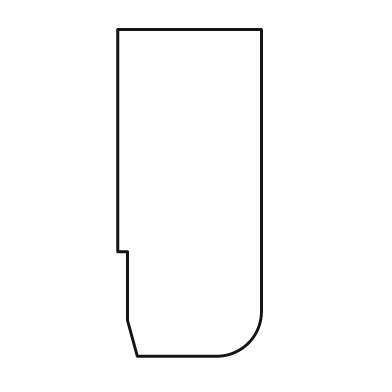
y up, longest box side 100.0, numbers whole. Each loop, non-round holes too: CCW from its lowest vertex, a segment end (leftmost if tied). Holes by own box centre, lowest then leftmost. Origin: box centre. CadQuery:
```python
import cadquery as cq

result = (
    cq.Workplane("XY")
    .moveTo(-16.0, -50.0)
    .lineTo(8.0, -50.0)
    .threePointArc((18.0, -46.0), (22.0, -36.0))
    .lineTo(22.0, 50.0)
    .lineTo(-22.0, 50.0)
    .lineTo(-22.0, -18.0)
    .lineTo(-19.0, -18.0)
    .lineTo(-19.0, -39.0)
    .close()
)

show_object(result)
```